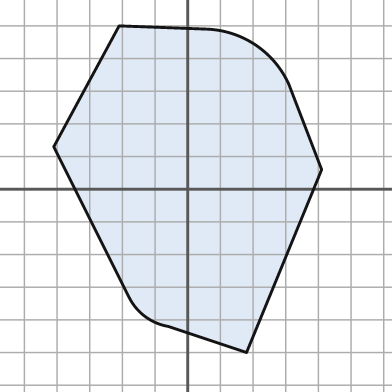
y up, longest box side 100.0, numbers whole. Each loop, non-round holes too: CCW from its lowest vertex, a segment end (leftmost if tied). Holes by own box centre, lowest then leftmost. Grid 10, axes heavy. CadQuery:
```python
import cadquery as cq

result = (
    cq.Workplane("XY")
    .moveTo(18.0, -50.0)
    .lineTo(41.0, 6.0)
    .lineTo(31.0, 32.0)
    .threePointArc((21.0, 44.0), (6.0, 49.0))
    .lineTo(-21.0, 50.0)
    .lineTo(-41.0, 13.0)
    .lineTo(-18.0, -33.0)
    .threePointArc((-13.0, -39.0), (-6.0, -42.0))
    .close()
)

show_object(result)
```